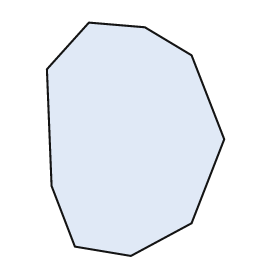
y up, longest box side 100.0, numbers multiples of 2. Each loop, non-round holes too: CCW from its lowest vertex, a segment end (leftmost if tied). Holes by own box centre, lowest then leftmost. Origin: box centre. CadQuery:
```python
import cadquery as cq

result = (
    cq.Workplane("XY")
    .moveTo(-2.0, -50.0)
    .lineTo(24.0, -36.0)
    .lineTo(38.0, 0.0)
    .lineTo(24.0, 36.0)
    .lineTo(4.0, 48.0)
    .lineTo(-20.0, 50.0)
    .lineTo(-38.0, 30.0)
    .lineTo(-36.0, -20.0)
    .lineTo(-26.0, -46.0)
    .close()
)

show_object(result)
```